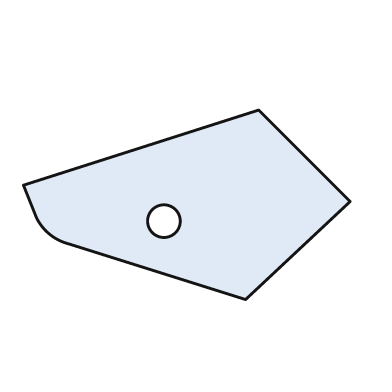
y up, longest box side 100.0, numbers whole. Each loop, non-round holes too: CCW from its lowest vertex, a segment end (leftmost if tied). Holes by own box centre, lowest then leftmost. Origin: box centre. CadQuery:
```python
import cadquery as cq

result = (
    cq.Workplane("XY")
    .moveTo(18.0, -29.0)
    .lineTo(50.0, 1.0)
    .lineTo(22.0, 29.0)
    .lineTo(-50.0, 6.0)
    .lineTo(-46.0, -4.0)
    .threePointArc((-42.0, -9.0), (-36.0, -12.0))
    .close()
    .moveTo(-7.0, -5.0)
    .circle(5.0)
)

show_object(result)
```